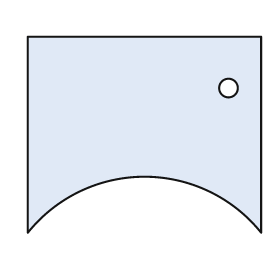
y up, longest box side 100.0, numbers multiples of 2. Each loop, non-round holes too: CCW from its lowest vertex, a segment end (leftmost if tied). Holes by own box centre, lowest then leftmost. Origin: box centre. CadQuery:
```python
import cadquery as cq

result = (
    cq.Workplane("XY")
    .moveTo(-50.0, -42.0)
    .threePointArc((0.0, -18.0), (50.0, -42.0))
    .lineTo(50.0, 42.0)
    .lineTo(-50.0, 42.0)
    .close()
    .moveTo(36.0, 20.0)
    .circle(4.0)
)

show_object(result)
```